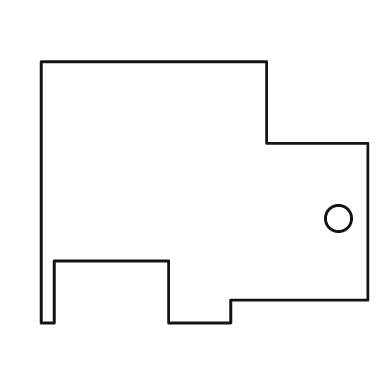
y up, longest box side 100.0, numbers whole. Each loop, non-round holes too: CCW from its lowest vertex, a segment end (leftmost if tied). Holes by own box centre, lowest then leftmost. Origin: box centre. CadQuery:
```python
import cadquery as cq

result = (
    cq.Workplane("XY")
    .moveTo(-50.0, -40.0)
    .lineTo(-46.0, -40.0)
    .lineTo(-46.0, -21.0)
    .lineTo(-11.0, -21.0)
    .lineTo(-11.0, -40.0)
    .lineTo(8.0, -40.0)
    .lineTo(8.0, -33.0)
    .lineTo(50.0, -33.0)
    .lineTo(50.0, 15.0)
    .lineTo(19.0, 15.0)
    .lineTo(19.0, 40.0)
    .lineTo(-50.0, 40.0)
    .close()
    .moveTo(41.0, -8.0)
    .circle(4.0)
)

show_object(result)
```